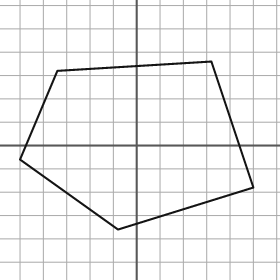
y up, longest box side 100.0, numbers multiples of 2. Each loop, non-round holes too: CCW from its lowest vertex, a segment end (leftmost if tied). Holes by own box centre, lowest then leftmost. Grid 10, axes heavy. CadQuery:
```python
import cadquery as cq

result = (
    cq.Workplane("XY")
    .moveTo(-8.0, -36.0)
    .lineTo(50.0, -18.0)
    .lineTo(32.0, 36.0)
    .lineTo(-34.0, 32.0)
    .lineTo(-50.0, -6.0)
    .close()
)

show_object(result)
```